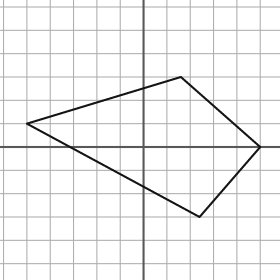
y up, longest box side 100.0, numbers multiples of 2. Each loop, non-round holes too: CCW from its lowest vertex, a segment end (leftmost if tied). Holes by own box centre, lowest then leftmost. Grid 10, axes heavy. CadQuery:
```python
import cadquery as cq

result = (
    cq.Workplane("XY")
    .moveTo(24.0, -30.0)
    .lineTo(50.0, 0.0)
    .lineTo(16.0, 30.0)
    .lineTo(-50.0, 10.0)
    .close()
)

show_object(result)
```